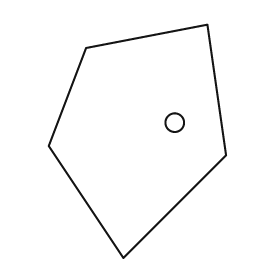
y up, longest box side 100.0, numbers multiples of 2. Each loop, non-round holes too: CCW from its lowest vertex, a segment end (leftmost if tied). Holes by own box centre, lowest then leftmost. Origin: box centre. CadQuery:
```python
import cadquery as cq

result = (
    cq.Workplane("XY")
    .moveTo(-6.0, -50.0)
    .lineTo(38.0, -6.0)
    .lineTo(30.0, 50.0)
    .lineTo(-22.0, 40.0)
    .lineTo(-38.0, -2.0)
    .close()
    .moveTo(16.0, 8.0)
    .circle(4.0)
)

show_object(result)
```